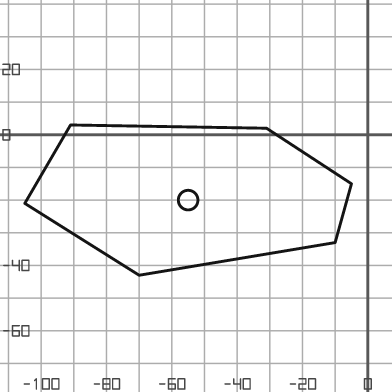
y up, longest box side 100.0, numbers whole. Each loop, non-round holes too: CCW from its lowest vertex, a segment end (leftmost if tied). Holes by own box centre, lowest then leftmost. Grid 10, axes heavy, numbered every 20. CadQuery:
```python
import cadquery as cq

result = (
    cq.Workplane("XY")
    .moveTo(-70.0, -43.0)
    .lineTo(-10.0, -33.0)
    .lineTo(-5.0, -15.0)
    .lineTo(-31.0, 2.0)
    .lineTo(-91.0, 3.0)
    .lineTo(-105.0, -21.0)
    .close()
    .moveTo(-55.0, -20.0)
    .circle(3.0)
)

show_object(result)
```